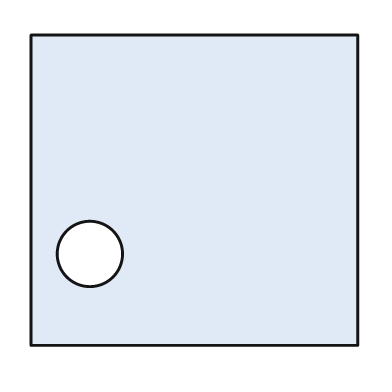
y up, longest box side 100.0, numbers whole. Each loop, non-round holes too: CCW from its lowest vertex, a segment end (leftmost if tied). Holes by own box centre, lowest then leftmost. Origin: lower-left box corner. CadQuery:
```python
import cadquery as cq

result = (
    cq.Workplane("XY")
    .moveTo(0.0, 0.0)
    .lineTo(100.0, 0.0)
    .lineTo(100.0, 95.0)
    .lineTo(0.0, 95.0)
    .close()
    .moveTo(18.0, 28.0)
    .circle(10.0)
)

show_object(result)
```